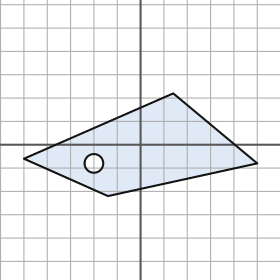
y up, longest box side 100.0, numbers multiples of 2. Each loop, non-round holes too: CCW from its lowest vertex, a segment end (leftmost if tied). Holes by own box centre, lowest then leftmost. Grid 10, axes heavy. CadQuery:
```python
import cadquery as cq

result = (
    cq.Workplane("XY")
    .moveTo(-14.0, -22.0)
    .lineTo(50.0, -8.0)
    .lineTo(14.0, 22.0)
    .lineTo(-50.0, -6.0)
    .close()
    .moveTo(-20.0, -8.0)
    .circle(4.0)
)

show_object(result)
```